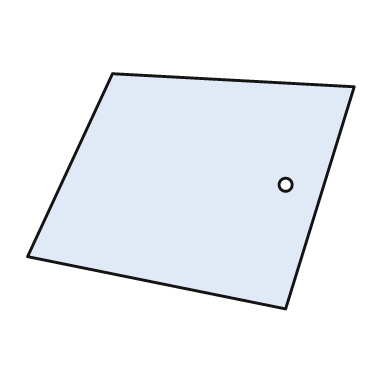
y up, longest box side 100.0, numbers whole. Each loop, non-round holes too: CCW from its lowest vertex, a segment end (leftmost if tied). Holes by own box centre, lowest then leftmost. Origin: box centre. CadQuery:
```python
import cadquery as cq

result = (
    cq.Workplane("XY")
    .moveTo(29.0, -36.0)
    .lineTo(50.0, 32.0)
    .lineTo(-24.0, 36.0)
    .lineTo(-50.0, -20.0)
    .close()
    .moveTo(29.0, 2.0)
    .circle(2.0)
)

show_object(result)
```